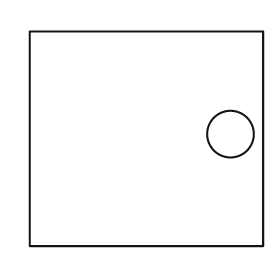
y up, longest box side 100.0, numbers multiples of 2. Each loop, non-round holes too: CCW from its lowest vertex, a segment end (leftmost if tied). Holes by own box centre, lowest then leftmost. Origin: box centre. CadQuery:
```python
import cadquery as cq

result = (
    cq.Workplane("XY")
    .moveTo(-50.0, -46.0)
    .lineTo(50.0, -46.0)
    .lineTo(50.0, 46.0)
    .lineTo(-50.0, 46.0)
    .close()
    .moveTo(36.0, 2.0)
    .circle(10.0)
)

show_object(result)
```